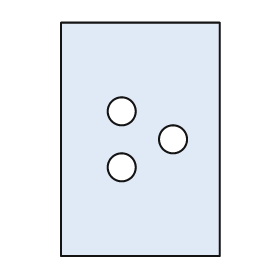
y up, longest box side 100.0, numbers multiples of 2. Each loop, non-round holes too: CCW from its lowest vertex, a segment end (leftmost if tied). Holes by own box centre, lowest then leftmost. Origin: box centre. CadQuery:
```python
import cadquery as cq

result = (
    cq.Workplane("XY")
    .moveTo(-34.0, -50.0)
    .lineTo(34.0, -50.0)
    .lineTo(34.0, 50.0)
    .lineTo(-34.0, 50.0)
    .close()
    .moveTo(-8.0, -12.0)
    .circle(6.0)
    .moveTo(14.0, 0.0)
    .circle(6.0)
    .moveTo(-8.0, 12.0)
    .circle(6.0)
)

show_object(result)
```